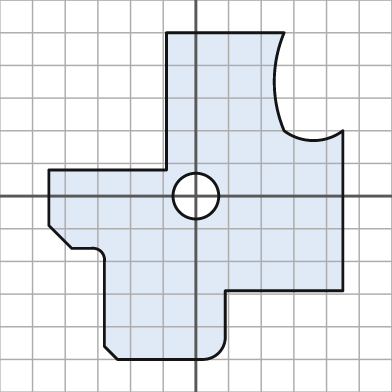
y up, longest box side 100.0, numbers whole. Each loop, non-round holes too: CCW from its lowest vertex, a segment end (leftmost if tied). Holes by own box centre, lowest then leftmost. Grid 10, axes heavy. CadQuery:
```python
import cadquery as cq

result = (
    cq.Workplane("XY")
    .moveTo(-24.0, -50.0)
    .lineTo(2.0, -50.0)
    .threePointArc((7.0, -48.0), (9.0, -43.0))
    .lineTo(9.0, -29.0)
    .lineTo(45.0, -29.0)
    .lineTo(45.0, 20.0)
    .threePointArc((36.0, 17.0), (27.0, 20.0))
    .threePointArc((24.0, 35.0), (27.0, 50.0))
    .lineTo(-9.0, 50.0)
    .lineTo(-9.0, 8.0)
    .lineTo(-45.0, 8.0)
    .lineTo(-45.0, -9.0)
    .lineTo(-38.0, -16.0)
    .lineTo(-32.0, -16.0)
    .threePointArc((-29.0, -17.0), (-28.0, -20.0))
    .lineTo(-28.0, -46.0)
    .close()
    .moveTo(0.0, 0.0)
    .circle(7.0)
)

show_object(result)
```